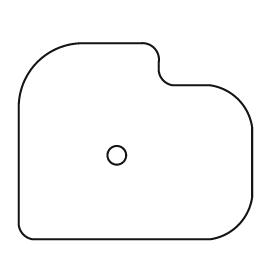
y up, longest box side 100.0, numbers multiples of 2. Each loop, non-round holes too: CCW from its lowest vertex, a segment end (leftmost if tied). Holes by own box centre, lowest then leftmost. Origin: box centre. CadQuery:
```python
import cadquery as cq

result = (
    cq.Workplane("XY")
    .moveTo(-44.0, -42.0)
    .lineTo(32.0, -42.0)
    .threePointArc((44.0, -36.0), (50.0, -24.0))
    .lineTo(50.0, 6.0)
    .threePointArc((44.0, 18.0), (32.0, 24.0))
    .lineTo(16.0, 24.0)
    .threePointArc((12.0, 26.0), (10.0, 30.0))
    .lineTo(10.0, 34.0)
    .threePointArc((8.0, 40.0), (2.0, 42.0))
    .lineTo(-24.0, 42.0)
    .threePointArc((-42.0, 34.0), (-50.0, 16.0))
    .lineTo(-50.0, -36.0)
    .threePointArc((-48.0, -40.0), (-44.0, -42.0))
    .close()
    .moveTo(-8.0, -6.0)
    .circle(4.0)
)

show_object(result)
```